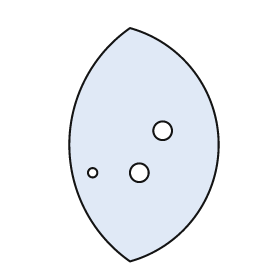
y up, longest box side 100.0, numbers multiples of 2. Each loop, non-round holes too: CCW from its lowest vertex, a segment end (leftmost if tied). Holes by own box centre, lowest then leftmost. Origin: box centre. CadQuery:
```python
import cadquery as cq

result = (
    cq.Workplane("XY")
    .moveTo(-6.0, -50.0)
    .threePointArc((32.0, 0.0), (-6.0, 50.0))
    .threePointArc((-32.0, 0.0), (-6.0, -50.0))
    .close()
    .moveTo(-22.0, -12.0)
    .circle(2.0)
    .moveTo(-2.0, -12.0)
    .circle(4.0)
    .moveTo(8.0, 6.0)
    .circle(4.0)
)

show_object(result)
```